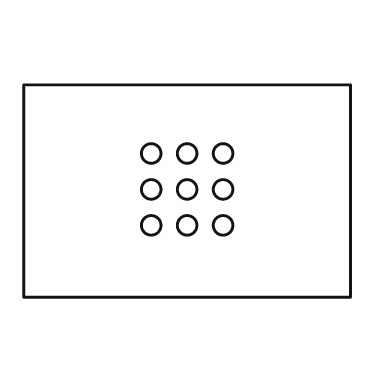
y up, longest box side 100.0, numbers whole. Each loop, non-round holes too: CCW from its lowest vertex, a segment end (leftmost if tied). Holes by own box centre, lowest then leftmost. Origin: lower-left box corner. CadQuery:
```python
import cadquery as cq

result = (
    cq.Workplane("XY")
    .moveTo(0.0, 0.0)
    .lineTo(100.0, 0.0)
    .lineTo(100.0, 65.0)
    .lineTo(0.0, 65.0)
    .close()
    .moveTo(39.0, 22.0)
    .circle(3.0)
    .moveTo(50.0, 22.0)
    .circle(3.0)
    .moveTo(61.0, 22.0)
    .circle(3.0)
    .moveTo(39.0, 33.0)
    .circle(3.0)
    .moveTo(50.0, 33.0)
    .circle(3.0)
    .moveTo(61.0, 33.0)
    .circle(3.0)
    .moveTo(39.0, 44.0)
    .circle(3.0)
    .moveTo(50.0, 44.0)
    .circle(3.0)
    .moveTo(61.0, 44.0)
    .circle(3.0)
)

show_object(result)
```